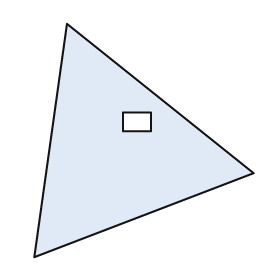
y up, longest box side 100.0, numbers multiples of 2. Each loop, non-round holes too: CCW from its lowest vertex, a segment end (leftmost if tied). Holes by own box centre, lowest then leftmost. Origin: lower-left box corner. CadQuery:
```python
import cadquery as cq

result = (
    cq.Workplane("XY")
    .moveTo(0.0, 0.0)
    .lineTo(94.0, 36.0)
    .lineTo(14.0, 100.0)
    .close()
    .moveTo(38.0, 54.0)
    .lineTo(50.0, 54.0)
    .lineTo(50.0, 62.0)
    .lineTo(38.0, 62.0)
    .close()
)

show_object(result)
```